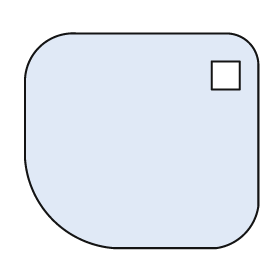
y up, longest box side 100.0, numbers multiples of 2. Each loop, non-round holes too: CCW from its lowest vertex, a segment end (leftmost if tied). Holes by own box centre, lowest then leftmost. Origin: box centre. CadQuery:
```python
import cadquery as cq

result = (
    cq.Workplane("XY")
    .moveTo(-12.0, -46.0)
    .lineTo(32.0, -46.0)
    .threePointArc((44.0, -40.0), (50.0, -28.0))
    .lineTo(50.0, 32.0)
    .threePointArc((46.0, 42.0), (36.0, 46.0))
    .lineTo(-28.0, 46.0)
    .threePointArc((-44.0, 40.0), (-50.0, 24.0))
    .lineTo(-50.0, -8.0)
    .threePointArc((-38.0, -34.0), (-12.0, -46.0))
    .close()
    .moveTo(30.0, 22.0)
    .lineTo(42.0, 22.0)
    .lineTo(42.0, 34.0)
    .lineTo(30.0, 34.0)
    .close()
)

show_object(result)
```